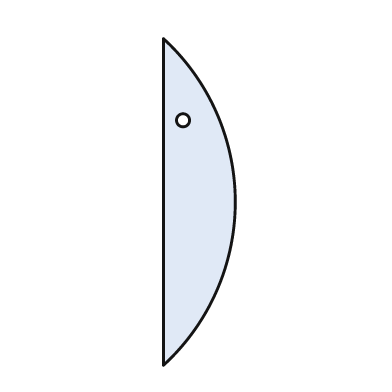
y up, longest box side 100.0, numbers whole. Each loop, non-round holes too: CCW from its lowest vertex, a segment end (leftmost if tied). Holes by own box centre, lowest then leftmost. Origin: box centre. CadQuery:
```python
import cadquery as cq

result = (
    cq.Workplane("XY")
    .moveTo(-11.0, -50.0)
    .threePointArc((11.0, 0.0), (-11.0, 50.0))
    .close()
    .moveTo(-5.0, 25.0)
    .circle(2.0)
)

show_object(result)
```